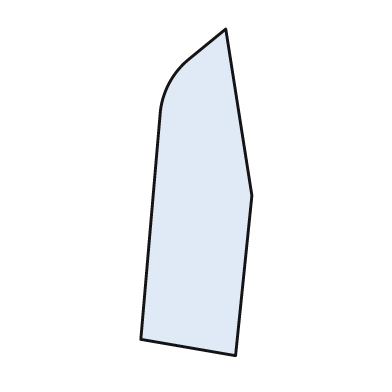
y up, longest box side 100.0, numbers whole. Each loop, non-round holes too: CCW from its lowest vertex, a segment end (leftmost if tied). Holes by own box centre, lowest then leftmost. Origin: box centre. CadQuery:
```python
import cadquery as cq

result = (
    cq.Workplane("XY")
    .moveTo(12.0, -50.0)
    .lineTo(17.0, -1.0)
    .lineTo(9.0, 50.0)
    .lineTo(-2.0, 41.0)
    .threePointArc((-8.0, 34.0), (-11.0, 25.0))
    .lineTo(-17.0, -45.0)
    .close()
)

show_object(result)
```